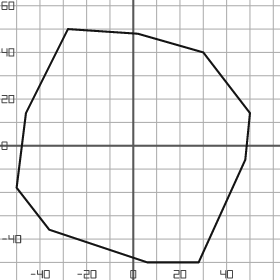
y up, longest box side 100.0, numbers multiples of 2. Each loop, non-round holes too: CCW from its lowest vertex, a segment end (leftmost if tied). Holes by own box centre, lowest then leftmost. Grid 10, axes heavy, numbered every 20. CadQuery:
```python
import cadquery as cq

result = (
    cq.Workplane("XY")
    .moveTo(6.0, -50.0)
    .lineTo(28.0, -50.0)
    .lineTo(48.0, -6.0)
    .lineTo(50.0, 14.0)
    .lineTo(30.0, 40.0)
    .lineTo(2.0, 48.0)
    .lineTo(-28.0, 50.0)
    .lineTo(-46.0, 14.0)
    .lineTo(-50.0, -18.0)
    .lineTo(-36.0, -36.0)
    .close()
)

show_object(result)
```